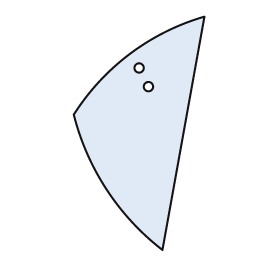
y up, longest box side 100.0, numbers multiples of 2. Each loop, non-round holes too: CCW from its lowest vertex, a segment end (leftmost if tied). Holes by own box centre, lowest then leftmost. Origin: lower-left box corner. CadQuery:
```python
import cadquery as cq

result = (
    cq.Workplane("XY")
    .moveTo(38.0, 0.0)
    .lineTo(56.0, 100.0)
    .threePointArc((24.0, 84.0), (0.0, 58.0))
    .threePointArc((14.0, 26.0), (38.0, 0.0))
    .close()
    .moveTo(32.0, 70.0)
    .circle(2.0)
    .moveTo(28.0, 78.0)
    .circle(2.0)
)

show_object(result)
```